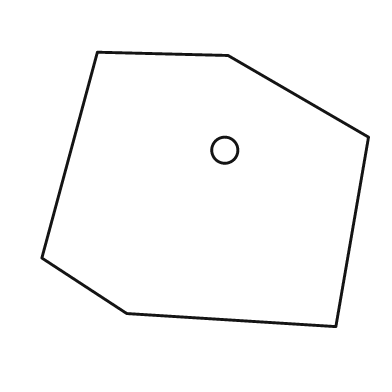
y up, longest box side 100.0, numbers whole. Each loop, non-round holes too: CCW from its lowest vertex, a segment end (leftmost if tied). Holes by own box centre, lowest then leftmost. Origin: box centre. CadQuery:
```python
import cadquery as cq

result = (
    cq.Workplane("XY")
    .moveTo(40.0, -42.0)
    .lineTo(50.0, 16.0)
    .lineTo(7.0, 41.0)
    .lineTo(-33.0, 42.0)
    .lineTo(-50.0, -21.0)
    .lineTo(-24.0, -38.0)
    .close()
    .moveTo(6.0, 12.0)
    .circle(4.0)
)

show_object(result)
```